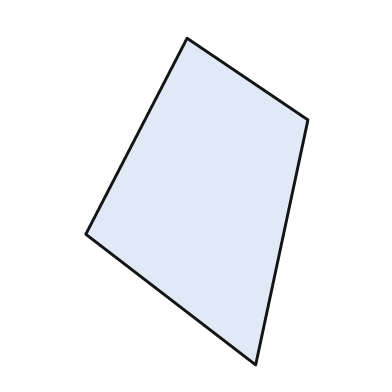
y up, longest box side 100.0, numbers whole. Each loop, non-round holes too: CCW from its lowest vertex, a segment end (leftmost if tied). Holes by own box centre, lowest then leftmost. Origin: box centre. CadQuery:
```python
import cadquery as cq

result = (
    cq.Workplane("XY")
    .moveTo(18.0, -50.0)
    .lineTo(34.0, 25.0)
    .lineTo(-3.0, 50.0)
    .lineTo(-34.0, -10.0)
    .close()
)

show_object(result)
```